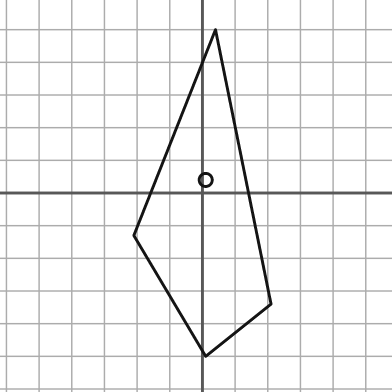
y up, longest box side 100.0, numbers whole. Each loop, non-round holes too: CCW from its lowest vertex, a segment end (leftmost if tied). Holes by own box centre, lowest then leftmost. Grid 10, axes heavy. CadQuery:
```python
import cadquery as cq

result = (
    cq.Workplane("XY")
    .moveTo(1.0, -50.0)
    .lineTo(21.0, -34.0)
    .lineTo(4.0, 50.0)
    .lineTo(-21.0, -13.0)
    .close()
    .moveTo(1.0, 4.0)
    .circle(2.0)
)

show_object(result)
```